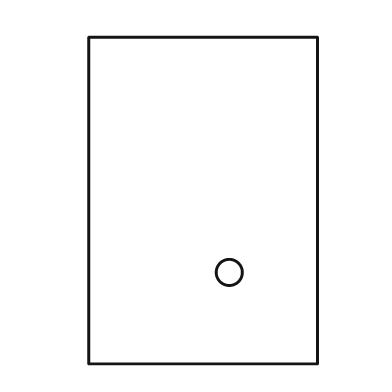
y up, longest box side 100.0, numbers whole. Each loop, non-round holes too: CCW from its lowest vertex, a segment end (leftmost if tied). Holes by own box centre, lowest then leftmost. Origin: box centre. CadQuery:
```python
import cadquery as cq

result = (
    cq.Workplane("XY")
    .moveTo(-35.0, -50.0)
    .lineTo(35.0, -50.0)
    .lineTo(35.0, 50.0)
    .lineTo(-35.0, 50.0)
    .close()
    .moveTo(8.0, -22.0)
    .circle(4.0)
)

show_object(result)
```